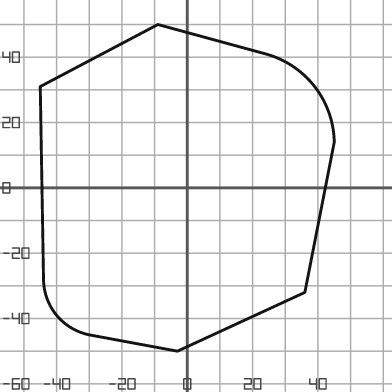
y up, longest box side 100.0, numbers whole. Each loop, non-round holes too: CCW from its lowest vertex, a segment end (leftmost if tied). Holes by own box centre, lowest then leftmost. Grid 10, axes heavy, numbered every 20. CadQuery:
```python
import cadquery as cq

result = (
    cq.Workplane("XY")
    .moveTo(-3.0, -50.0)
    .lineTo(36.0, -32.0)
    .lineTo(45.0, 14.0)
    .threePointArc((39.0, 31.0), (24.0, 41.0))
    .lineTo(-9.0, 50.0)
    .lineTo(-45.0, 31.0)
    .lineTo(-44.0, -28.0)
    .threePointArc((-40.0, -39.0), (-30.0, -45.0))
    .close()
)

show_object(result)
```